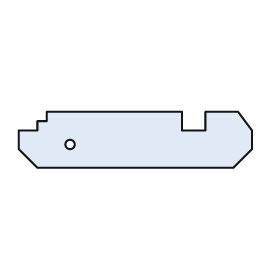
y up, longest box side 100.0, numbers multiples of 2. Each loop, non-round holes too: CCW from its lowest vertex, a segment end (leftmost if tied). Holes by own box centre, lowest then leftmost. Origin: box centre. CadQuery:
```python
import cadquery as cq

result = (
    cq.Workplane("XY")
    .moveTo(-42.0, -12.0)
    .lineTo(42.0, -12.0)
    .lineTo(50.0, -4.0)
    .lineTo(50.0, 4.0)
    .lineTo(44.0, 12.0)
    .lineTo(30.0, 12.0)
    .lineTo(30.0, 4.0)
    .lineTo(20.0, 4.0)
    .lineTo(20.0, 12.0)
    .lineTo(-38.0, 12.0)
    .lineTo(-38.0, 8.0)
    .lineTo(-42.0, 8.0)
    .lineTo(-42.0, 4.0)
    .lineTo(-50.0, 4.0)
    .lineTo(-50.0, -4.0)
    .close()
    .moveTo(-28.0, -2.0)
    .circle(2.0)
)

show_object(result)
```